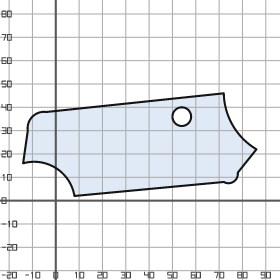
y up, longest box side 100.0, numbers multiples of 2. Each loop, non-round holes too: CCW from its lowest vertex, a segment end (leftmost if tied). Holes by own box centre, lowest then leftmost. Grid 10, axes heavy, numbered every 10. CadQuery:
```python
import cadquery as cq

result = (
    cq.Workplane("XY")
    .moveTo(8.0, 2.0)
    .lineTo(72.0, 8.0)
    .threePointArc((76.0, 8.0), (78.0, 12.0))
    .lineTo(86.0, 22.0)
    .threePointArc((76.0, 32.0), (72.0, 46.0))
    .lineTo(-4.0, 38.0)
    .threePointArc((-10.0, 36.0), (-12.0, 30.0))
    .lineTo(-14.0, 16.0)
    .threePointArc((0.0, 14.0), (8.0, 2.0))
    .close()
    .moveTo(54.0, 36.0)
    .circle(4.0)
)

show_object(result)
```